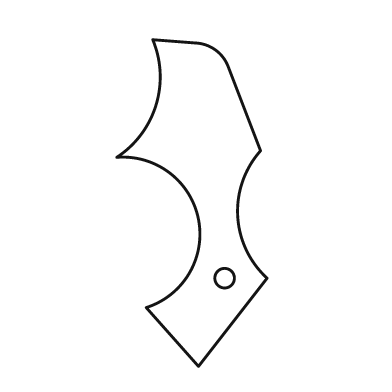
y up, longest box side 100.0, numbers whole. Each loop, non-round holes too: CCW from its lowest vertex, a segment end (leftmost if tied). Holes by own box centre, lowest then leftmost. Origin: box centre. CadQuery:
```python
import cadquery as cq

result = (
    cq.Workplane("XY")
    .moveTo(2.0, -50.0)
    .lineTo(23.0, -23.0)
    .threePointArc((14.0, -4.0), (21.0, 16.0))
    .lineTo(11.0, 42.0)
    .threePointArc((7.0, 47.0), (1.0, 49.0))
    .lineTo(-12.0, 50.0)
    .threePointArc((-11.0, 30.0), (-23.0, 14.0))
    .threePointArc((2.0, -5.0), (-14.0, -32.0))
    .close()
    .moveTo(10.0, -23.0)
    .circle(3.0)
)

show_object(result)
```